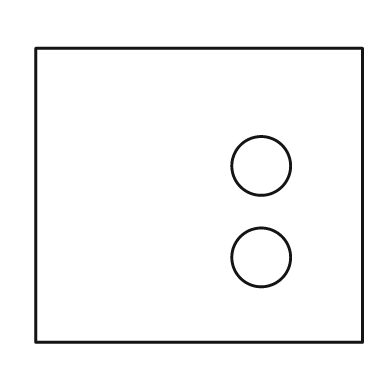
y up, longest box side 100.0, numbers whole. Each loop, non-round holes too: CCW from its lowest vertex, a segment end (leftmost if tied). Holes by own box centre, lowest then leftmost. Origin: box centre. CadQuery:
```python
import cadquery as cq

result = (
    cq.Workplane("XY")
    .moveTo(-50.0, -45.0)
    .lineTo(50.0, -45.0)
    .lineTo(50.0, 45.0)
    .lineTo(-50.0, 45.0)
    .close()
    .moveTo(19.0, -19.0)
    .circle(9.0)
    .moveTo(19.0, 9.0)
    .circle(9.0)
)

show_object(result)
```